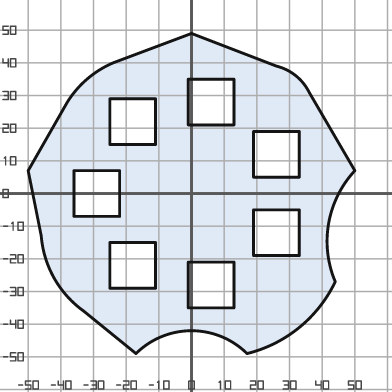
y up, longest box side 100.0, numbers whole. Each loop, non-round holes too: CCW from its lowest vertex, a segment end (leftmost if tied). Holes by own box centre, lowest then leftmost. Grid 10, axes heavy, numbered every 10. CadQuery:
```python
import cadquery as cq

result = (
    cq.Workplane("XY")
    .moveTo(-17.0, -49.0)
    .threePointArc((0.0, -42.0), (17.0, -49.0))
    .threePointArc((33.0, -41.0), (44.0, -27.0))
    .threePointArc((42.0, -9.0), (50.0, 7.0))
    .lineTo(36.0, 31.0)
    .threePointArc((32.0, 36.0), (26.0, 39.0))
    .lineTo(0.0, 49.0)
    .lineTo(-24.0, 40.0)
    .threePointArc((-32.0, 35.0), (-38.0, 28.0))
    .lineTo(-50.0, 7.0)
    .lineTo(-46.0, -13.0)
    .threePointArc((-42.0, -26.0), (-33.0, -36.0))
    .close()
    .moveTo(-1.0, -35.0)
    .lineTo(13.0, -35.0)
    .lineTo(13.0, -21.0)
    .lineTo(-1.0, -21.0)
    .close()
    .moveTo(-25.0, -29.0)
    .lineTo(-11.0, -29.0)
    .lineTo(-11.0, -15.0)
    .lineTo(-25.0, -15.0)
    .close()
    .moveTo(19.0, -19.0)
    .lineTo(33.0, -19.0)
    .lineTo(33.0, -5.0)
    .lineTo(19.0, -5.0)
    .close()
    .moveTo(-36.0, -7.0)
    .lineTo(-22.0, -7.0)
    .lineTo(-22.0, 7.0)
    .lineTo(-36.0, 7.0)
    .close()
    .moveTo(19.0, 5.0)
    .lineTo(33.0, 5.0)
    .lineTo(33.0, 19.0)
    .lineTo(19.0, 19.0)
    .close()
    .moveTo(-25.0, 15.0)
    .lineTo(-11.0, 15.0)
    .lineTo(-11.0, 29.0)
    .lineTo(-25.0, 29.0)
    .close()
    .moveTo(-1.0, 21.0)
    .lineTo(13.0, 21.0)
    .lineTo(13.0, 35.0)
    .lineTo(-1.0, 35.0)
    .close()
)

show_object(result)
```